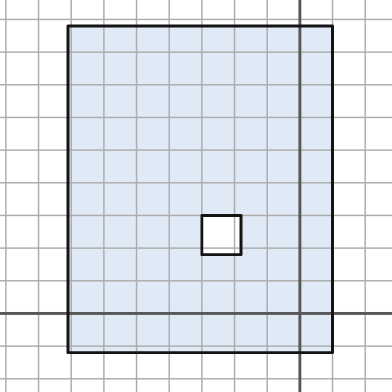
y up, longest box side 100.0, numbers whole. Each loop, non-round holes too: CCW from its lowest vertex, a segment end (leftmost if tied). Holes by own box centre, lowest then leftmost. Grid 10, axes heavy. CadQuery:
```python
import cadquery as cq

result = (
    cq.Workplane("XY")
    .moveTo(-71.0, -12.0)
    .lineTo(10.0, -12.0)
    .lineTo(10.0, 88.0)
    .lineTo(-71.0, 88.0)
    .close()
    .moveTo(-30.0, 18.0)
    .lineTo(-18.0, 18.0)
    .lineTo(-18.0, 30.0)
    .lineTo(-30.0, 30.0)
    .close()
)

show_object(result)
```